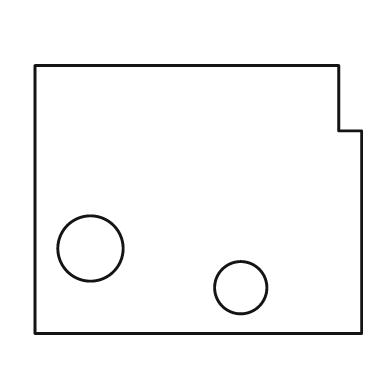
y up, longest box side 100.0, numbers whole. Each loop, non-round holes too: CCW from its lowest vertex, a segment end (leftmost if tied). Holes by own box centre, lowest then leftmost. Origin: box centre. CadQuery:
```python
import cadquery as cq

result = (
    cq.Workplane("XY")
    .moveTo(-50.0, -41.0)
    .lineTo(50.0, -41.0)
    .lineTo(50.0, 21.0)
    .lineTo(43.0, 21.0)
    .lineTo(43.0, 41.0)
    .lineTo(-50.0, 41.0)
    .close()
    .moveTo(13.0, -27.0)
    .circle(8.0)
    .moveTo(-33.0, -15.0)
    .circle(10.0)
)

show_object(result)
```